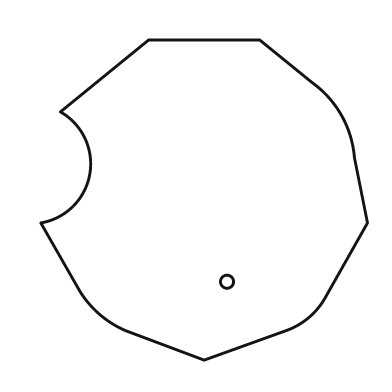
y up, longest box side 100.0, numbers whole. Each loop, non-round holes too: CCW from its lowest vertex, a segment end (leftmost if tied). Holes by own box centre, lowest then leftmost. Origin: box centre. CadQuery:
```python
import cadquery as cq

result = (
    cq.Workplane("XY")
    .moveTo(0.0, -49.0)
    .lineTo(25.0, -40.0)
    .threePointArc((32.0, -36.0), (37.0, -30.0))
    .lineTo(50.0, -7.0)
    .lineTo(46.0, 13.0)
    .threePointArc((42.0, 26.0), (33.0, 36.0))
    .lineTo(17.0, 49.0)
    .lineTo(-17.0, 49.0)
    .lineTo(-44.0, 27.0)
    .threePointArc((-35.0, 8.0), (-50.0, -7.0))
    .lineTo(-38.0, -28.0)
    .threePointArc((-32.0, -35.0), (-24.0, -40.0))
    .close()
    .moveTo(7.0, -25.0)
    .circle(2.0)
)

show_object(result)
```